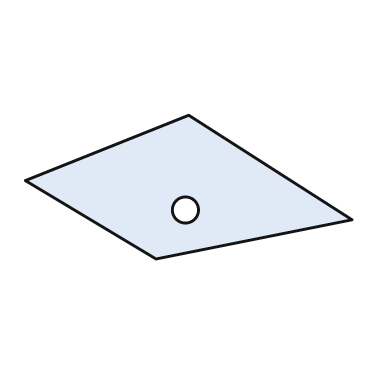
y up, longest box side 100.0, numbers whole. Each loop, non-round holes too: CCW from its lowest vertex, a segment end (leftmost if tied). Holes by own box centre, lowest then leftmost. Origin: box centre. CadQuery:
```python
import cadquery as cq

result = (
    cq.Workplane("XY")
    .moveTo(-10.0, -22.0)
    .lineTo(50.0, -10.0)
    .lineTo(0.0, 22.0)
    .lineTo(-50.0, 2.0)
    .close()
    .moveTo(-1.0, -7.0)
    .circle(4.0)
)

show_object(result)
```